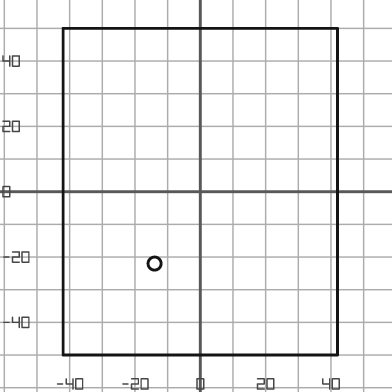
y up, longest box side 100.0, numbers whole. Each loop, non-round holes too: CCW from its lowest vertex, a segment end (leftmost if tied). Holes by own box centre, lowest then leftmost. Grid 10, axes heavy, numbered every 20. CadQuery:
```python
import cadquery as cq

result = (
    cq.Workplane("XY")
    .moveTo(-42.0, -50.0)
    .lineTo(42.0, -50.0)
    .lineTo(42.0, 50.0)
    .lineTo(-42.0, 50.0)
    .close()
    .moveTo(-14.0, -22.0)
    .circle(2.0)
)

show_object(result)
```